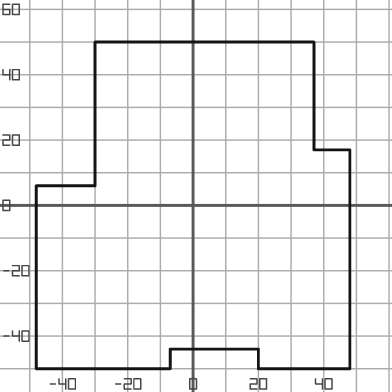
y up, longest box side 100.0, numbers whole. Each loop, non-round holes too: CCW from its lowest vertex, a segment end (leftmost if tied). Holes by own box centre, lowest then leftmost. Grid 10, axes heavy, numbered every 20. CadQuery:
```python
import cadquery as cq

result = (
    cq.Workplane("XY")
    .moveTo(-48.0, -50.0)
    .lineTo(-7.0, -50.0)
    .lineTo(-7.0, -44.0)
    .lineTo(20.0, -44.0)
    .lineTo(20.0, -50.0)
    .lineTo(48.0, -50.0)
    .lineTo(48.0, 17.0)
    .lineTo(37.0, 17.0)
    .lineTo(37.0, 50.0)
    .lineTo(-30.0, 50.0)
    .lineTo(-30.0, 6.0)
    .lineTo(-48.0, 6.0)
    .close()
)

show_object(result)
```